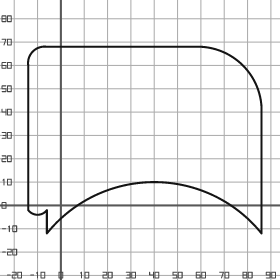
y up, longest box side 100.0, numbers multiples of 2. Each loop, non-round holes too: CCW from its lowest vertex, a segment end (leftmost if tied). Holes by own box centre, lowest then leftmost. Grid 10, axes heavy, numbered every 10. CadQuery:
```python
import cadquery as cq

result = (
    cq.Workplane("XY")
    .moveTo(-6.0, -12.0)
    .threePointArc((40.0, 10.0), (86.0, -12.0))
    .lineTo(86.0, 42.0)
    .threePointArc((78.0, 60.0), (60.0, 68.0))
    .lineTo(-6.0, 68.0)
    .threePointArc((-12.0, 66.0), (-14.0, 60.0))
    .lineTo(-14.0, -2.0)
    .threePointArc((-10.0, -4.0), (-6.0, -2.0))
    .close()
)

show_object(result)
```